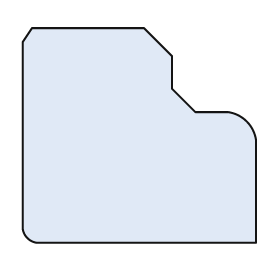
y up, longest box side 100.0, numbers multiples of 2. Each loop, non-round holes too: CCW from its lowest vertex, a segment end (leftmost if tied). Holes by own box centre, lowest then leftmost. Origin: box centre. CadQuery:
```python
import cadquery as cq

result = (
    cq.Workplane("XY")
    .moveTo(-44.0, -46.0)
    .lineTo(50.0, -46.0)
    .lineTo(50.0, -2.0)
    .threePointArc((46.0, 6.0), (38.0, 10.0))
    .lineTo(24.0, 10.0)
    .lineTo(14.0, 20.0)
    .lineTo(14.0, 34.0)
    .lineTo(2.0, 46.0)
    .lineTo(-46.0, 46.0)
    .lineTo(-50.0, 40.0)
    .lineTo(-50.0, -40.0)
    .threePointArc((-48.0, -44.0), (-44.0, -46.0))
    .close()
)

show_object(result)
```